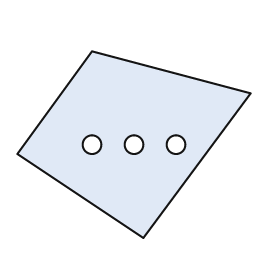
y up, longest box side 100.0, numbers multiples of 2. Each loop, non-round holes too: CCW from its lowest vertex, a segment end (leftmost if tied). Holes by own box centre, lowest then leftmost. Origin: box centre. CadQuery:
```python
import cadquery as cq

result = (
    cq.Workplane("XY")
    .moveTo(4.0, -40.0)
    .lineTo(50.0, 22.0)
    .lineTo(-18.0, 40.0)
    .lineTo(-50.0, -4.0)
    .close()
    .moveTo(-18.0, 0.0)
    .circle(4.0)
    .moveTo(0.0, 0.0)
    .circle(4.0)
    .moveTo(18.0, 0.0)
    .circle(4.0)
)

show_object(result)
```